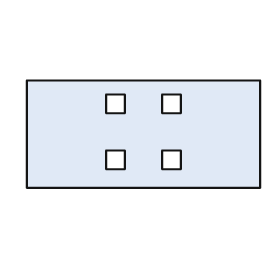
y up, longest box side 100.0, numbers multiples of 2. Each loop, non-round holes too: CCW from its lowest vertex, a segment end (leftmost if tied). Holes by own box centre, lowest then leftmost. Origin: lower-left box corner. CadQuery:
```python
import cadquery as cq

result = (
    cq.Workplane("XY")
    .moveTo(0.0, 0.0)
    .lineTo(100.0, 0.0)
    .lineTo(100.0, 46.0)
    .lineTo(0.0, 46.0)
    .close()
    .moveTo(34.0, 8.0)
    .lineTo(42.0, 8.0)
    .lineTo(42.0, 16.0)
    .lineTo(34.0, 16.0)
    .close()
    .moveTo(58.0, 8.0)
    .lineTo(66.0, 8.0)
    .lineTo(66.0, 16.0)
    .lineTo(58.0, 16.0)
    .close()
    .moveTo(34.0, 32.0)
    .lineTo(42.0, 32.0)
    .lineTo(42.0, 40.0)
    .lineTo(34.0, 40.0)
    .close()
    .moveTo(58.0, 32.0)
    .lineTo(66.0, 32.0)
    .lineTo(66.0, 40.0)
    .lineTo(58.0, 40.0)
    .close()
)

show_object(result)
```